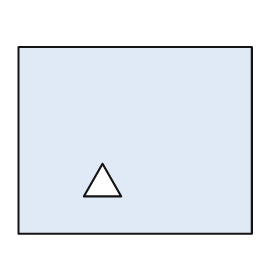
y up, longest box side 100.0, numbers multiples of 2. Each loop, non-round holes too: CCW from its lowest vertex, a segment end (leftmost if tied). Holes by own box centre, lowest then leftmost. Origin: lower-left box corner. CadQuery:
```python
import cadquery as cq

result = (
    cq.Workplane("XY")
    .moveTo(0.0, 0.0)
    .lineTo(100.0, 0.0)
    .lineTo(100.0, 80.0)
    .lineTo(0.0, 80.0)
    .close()
    .moveTo(28.0, 16.0)
    .lineTo(44.0, 16.0)
    .lineTo(36.0, 30.0)
    .close()
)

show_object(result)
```